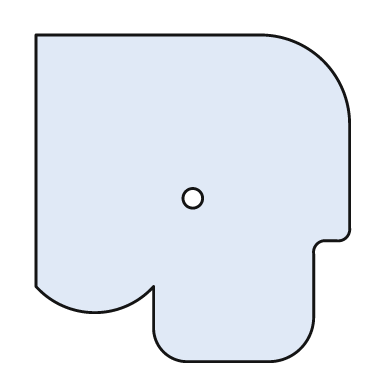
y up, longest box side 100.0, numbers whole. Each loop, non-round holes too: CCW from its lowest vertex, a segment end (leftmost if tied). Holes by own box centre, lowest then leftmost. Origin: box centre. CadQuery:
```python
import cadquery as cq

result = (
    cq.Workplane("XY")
    .moveTo(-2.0, -50.0)
    .lineTo(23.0, -50.0)
    .threePointArc((33.0, -46.0), (37.0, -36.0))
    .lineTo(37.0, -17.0)
    .threePointArc((38.0, -14.0), (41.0, -13.0))
    .lineTo(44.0, -13.0)
    .threePointArc((47.0, -12.0), (48.0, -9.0))
    .lineTo(48.0, 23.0)
    .threePointArc((40.0, 42.0), (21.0, 50.0))
    .lineTo(-48.0, 50.0)
    .lineTo(-48.0, -27.0)
    .threePointArc((-30.0, -35.0), (-12.0, -27.0))
    .lineTo(-12.0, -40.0)
    .threePointArc((-9.0, -47.0), (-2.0, -50.0))
    .close()
    .moveTo(0.0, 0.0)
    .circle(3.0)
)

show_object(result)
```